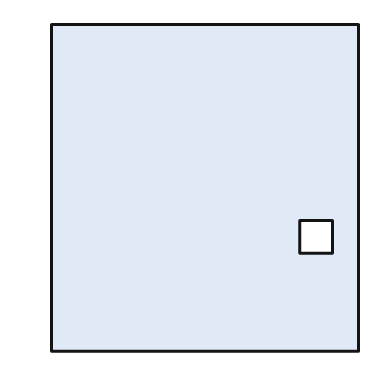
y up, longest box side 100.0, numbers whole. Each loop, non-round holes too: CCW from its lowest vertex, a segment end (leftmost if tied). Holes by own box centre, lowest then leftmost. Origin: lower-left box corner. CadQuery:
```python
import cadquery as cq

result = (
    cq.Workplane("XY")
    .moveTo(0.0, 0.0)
    .lineTo(94.0, 0.0)
    .lineTo(94.0, 100.0)
    .lineTo(0.0, 100.0)
    .close()
    .moveTo(76.0, 30.0)
    .lineTo(86.0, 30.0)
    .lineTo(86.0, 40.0)
    .lineTo(76.0, 40.0)
    .close()
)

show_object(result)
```